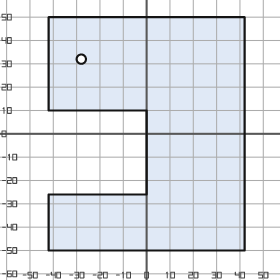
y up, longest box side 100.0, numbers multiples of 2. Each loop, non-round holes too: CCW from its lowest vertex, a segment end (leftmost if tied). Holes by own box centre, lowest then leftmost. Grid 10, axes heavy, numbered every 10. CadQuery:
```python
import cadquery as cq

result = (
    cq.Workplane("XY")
    .moveTo(-42.0, -50.0)
    .lineTo(42.0, -50.0)
    .lineTo(42.0, 50.0)
    .lineTo(-42.0, 50.0)
    .lineTo(-42.0, 10.0)
    .lineTo(0.0, 10.0)
    .lineTo(0.0, -26.0)
    .lineTo(-42.0, -26.0)
    .close()
    .moveTo(-28.0, 32.0)
    .circle(2.0)
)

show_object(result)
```